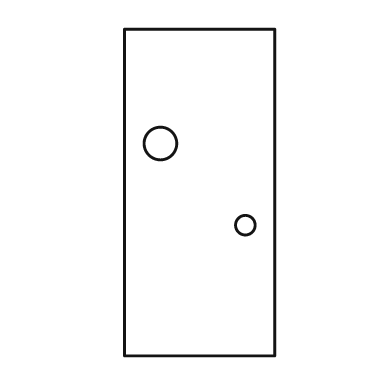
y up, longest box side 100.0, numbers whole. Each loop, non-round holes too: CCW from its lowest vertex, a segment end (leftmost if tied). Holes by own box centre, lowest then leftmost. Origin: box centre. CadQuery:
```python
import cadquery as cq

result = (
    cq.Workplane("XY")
    .moveTo(-23.0, -50.0)
    .lineTo(23.0, -50.0)
    .lineTo(23.0, 50.0)
    .lineTo(-23.0, 50.0)
    .close()
    .moveTo(14.0, -10.0)
    .circle(3.0)
    .moveTo(-12.0, 15.0)
    .circle(5.0)
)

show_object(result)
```